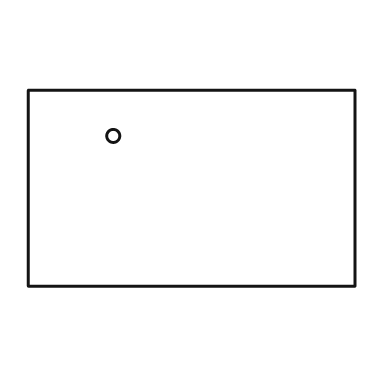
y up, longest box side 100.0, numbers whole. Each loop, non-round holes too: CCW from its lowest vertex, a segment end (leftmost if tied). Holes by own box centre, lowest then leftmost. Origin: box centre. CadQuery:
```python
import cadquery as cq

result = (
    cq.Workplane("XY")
    .moveTo(-50.0, -30.0)
    .lineTo(50.0, -30.0)
    .lineTo(50.0, 30.0)
    .lineTo(-50.0, 30.0)
    .close()
    .moveTo(-24.0, 16.0)
    .circle(2.0)
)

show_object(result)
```